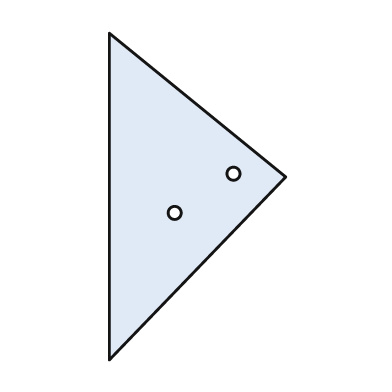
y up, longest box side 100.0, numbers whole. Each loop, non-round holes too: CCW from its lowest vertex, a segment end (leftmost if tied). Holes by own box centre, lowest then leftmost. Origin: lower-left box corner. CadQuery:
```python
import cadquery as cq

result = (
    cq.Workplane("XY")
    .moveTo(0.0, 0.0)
    .lineTo(54.0, 56.0)
    .lineTo(0.0, 100.0)
    .close()
    .moveTo(20.0, 45.0)
    .circle(2.0)
    .moveTo(38.0, 57.0)
    .circle(2.0)
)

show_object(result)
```